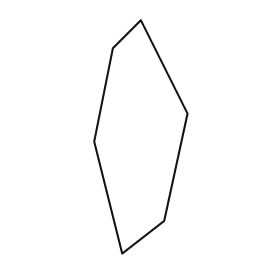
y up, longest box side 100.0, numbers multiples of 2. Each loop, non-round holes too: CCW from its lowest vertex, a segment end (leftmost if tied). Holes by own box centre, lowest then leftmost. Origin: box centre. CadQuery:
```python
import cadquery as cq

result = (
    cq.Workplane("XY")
    .moveTo(-8.0, -50.0)
    .lineTo(10.0, -36.0)
    .lineTo(20.0, 10.0)
    .lineTo(0.0, 50.0)
    .lineTo(-12.0, 38.0)
    .lineTo(-20.0, -2.0)
    .close()
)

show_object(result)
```